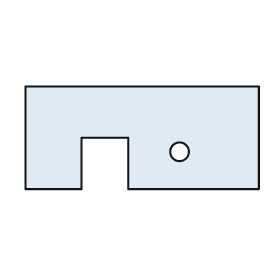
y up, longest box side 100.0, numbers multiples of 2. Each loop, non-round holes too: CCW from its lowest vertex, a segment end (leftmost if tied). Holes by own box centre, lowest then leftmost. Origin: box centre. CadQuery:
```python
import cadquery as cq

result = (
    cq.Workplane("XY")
    .moveTo(-50.0, -22.0)
    .lineTo(-26.0, -22.0)
    .lineTo(-26.0, 0.0)
    .lineTo(-6.0, 0.0)
    .lineTo(-6.0, -22.0)
    .lineTo(50.0, -22.0)
    .lineTo(50.0, 22.0)
    .lineTo(-50.0, 22.0)
    .close()
    .moveTo(16.0, -6.0)
    .circle(4.0)
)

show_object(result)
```